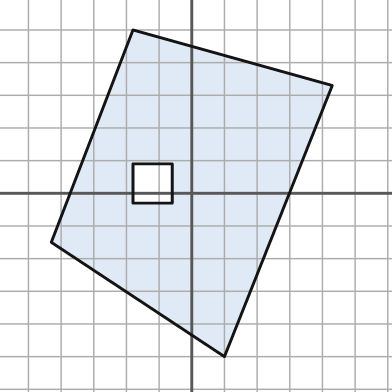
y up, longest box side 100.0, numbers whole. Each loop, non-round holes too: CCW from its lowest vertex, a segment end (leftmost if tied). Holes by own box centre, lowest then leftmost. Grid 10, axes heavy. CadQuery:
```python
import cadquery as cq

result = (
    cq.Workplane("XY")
    .moveTo(10.0, -50.0)
    .lineTo(43.0, 33.0)
    .lineTo(-18.0, 50.0)
    .lineTo(-43.0, -15.0)
    .close()
    .moveTo(-18.0, -3.0)
    .lineTo(-6.0, -3.0)
    .lineTo(-6.0, 9.0)
    .lineTo(-18.0, 9.0)
    .close()
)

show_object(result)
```